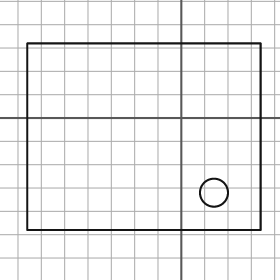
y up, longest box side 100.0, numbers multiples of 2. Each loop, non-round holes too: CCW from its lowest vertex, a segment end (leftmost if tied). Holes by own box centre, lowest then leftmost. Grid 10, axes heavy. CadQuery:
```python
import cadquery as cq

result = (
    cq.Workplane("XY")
    .moveTo(-66.0, -48.0)
    .lineTo(34.0, -48.0)
    .lineTo(34.0, 32.0)
    .lineTo(-66.0, 32.0)
    .close()
    .moveTo(14.0, -32.0)
    .circle(6.0)
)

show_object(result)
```